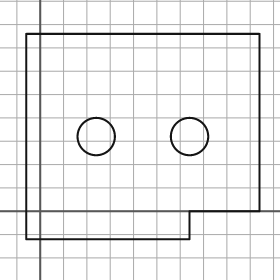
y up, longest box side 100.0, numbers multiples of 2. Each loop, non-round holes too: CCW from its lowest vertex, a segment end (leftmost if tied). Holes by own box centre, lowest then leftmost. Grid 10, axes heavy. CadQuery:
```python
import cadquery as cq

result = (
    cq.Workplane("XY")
    .moveTo(-6.0, -12.0)
    .lineTo(64.0, -12.0)
    .lineTo(64.0, 0.0)
    .lineTo(94.0, 0.0)
    .lineTo(94.0, 76.0)
    .lineTo(-6.0, 76.0)
    .close()
    .moveTo(24.0, 32.0)
    .circle(8.0)
    .moveTo(64.0, 32.0)
    .circle(8.0)
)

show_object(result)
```